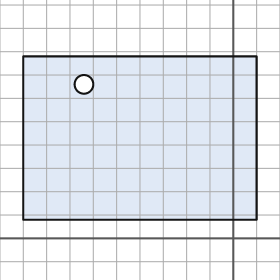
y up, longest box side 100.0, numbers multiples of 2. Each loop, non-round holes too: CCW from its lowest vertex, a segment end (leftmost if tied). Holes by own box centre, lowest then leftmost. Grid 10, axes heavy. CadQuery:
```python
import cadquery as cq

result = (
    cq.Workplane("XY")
    .moveTo(-90.0, 8.0)
    .lineTo(10.0, 8.0)
    .lineTo(10.0, 78.0)
    .lineTo(-90.0, 78.0)
    .close()
    .moveTo(-64.0, 66.0)
    .circle(4.0)
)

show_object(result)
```